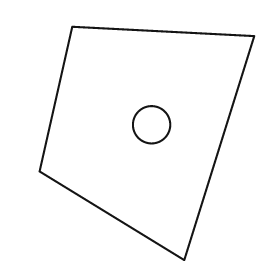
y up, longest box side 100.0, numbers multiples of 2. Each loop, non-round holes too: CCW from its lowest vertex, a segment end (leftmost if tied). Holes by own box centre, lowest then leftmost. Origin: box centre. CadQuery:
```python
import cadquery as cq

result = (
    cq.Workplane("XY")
    .moveTo(16.0, -50.0)
    .lineTo(46.0, 46.0)
    .lineTo(-32.0, 50.0)
    .lineTo(-46.0, -12.0)
    .close()
    .moveTo(2.0, 8.0)
    .circle(8.0)
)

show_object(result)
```